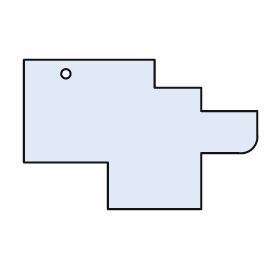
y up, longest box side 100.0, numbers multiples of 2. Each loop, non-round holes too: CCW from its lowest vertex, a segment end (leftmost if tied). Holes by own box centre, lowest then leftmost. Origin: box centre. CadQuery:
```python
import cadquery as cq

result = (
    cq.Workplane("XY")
    .moveTo(-14.0, -32.0)
    .lineTo(26.0, -32.0)
    .lineTo(26.0, -8.0)
    .lineTo(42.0, -8.0)
    .threePointArc((48.0, -6.0), (50.0, 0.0))
    .lineTo(50.0, 10.0)
    .lineTo(26.0, 10.0)
    .lineTo(26.0, 20.0)
    .lineTo(6.0, 20.0)
    .lineTo(6.0, 32.0)
    .lineTo(-50.0, 32.0)
    .lineTo(-50.0, -12.0)
    .lineTo(-14.0, -12.0)
    .close()
    .moveTo(-32.0, 26.0)
    .circle(2.0)
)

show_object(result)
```